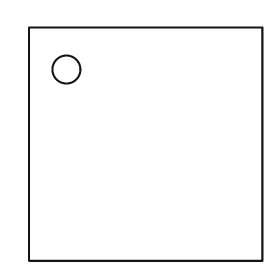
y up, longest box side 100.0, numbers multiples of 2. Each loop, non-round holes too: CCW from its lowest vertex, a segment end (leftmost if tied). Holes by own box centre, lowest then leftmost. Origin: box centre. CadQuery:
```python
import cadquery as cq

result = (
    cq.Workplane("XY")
    .moveTo(-50.0, -50.0)
    .lineTo(50.0, -50.0)
    .lineTo(50.0, 50.0)
    .lineTo(-50.0, 50.0)
    .close()
    .moveTo(-34.0, 32.0)
    .circle(6.0)
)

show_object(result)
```